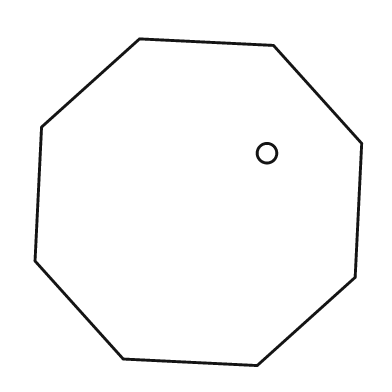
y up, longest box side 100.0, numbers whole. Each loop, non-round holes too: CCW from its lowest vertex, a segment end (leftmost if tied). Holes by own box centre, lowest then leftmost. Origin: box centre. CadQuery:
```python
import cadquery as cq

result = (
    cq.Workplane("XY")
    .moveTo(18.0, -50.0)
    .lineTo(48.0, -23.0)
    .lineTo(50.0, 18.0)
    .lineTo(23.0, 48.0)
    .lineTo(-18.0, 50.0)
    .lineTo(-48.0, 23.0)
    .lineTo(-50.0, -18.0)
    .lineTo(-23.0, -48.0)
    .close()
    .moveTo(21.0, 15.0)
    .circle(3.0)
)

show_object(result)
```